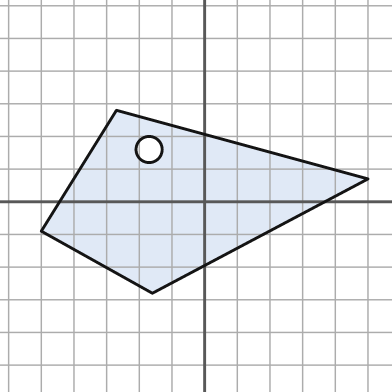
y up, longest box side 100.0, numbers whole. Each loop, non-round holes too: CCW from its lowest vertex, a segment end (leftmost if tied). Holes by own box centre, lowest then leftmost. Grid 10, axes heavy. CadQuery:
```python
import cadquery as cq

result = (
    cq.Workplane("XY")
    .moveTo(-16.0, -28.0)
    .lineTo(50.0, 7.0)
    .lineTo(-27.0, 28.0)
    .lineTo(-50.0, -9.0)
    .close()
    .moveTo(-17.0, 16.0)
    .circle(4.0)
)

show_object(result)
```